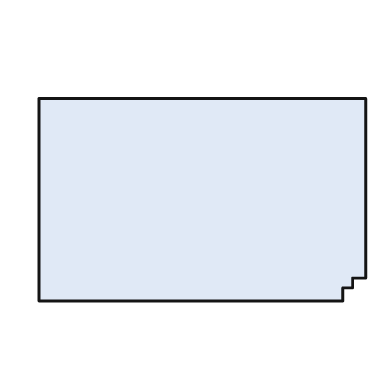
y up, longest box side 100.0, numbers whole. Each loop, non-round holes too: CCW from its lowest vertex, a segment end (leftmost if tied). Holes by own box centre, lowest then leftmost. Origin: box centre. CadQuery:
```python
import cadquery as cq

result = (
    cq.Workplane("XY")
    .moveTo(-50.0, -31.0)
    .lineTo(43.0, -31.0)
    .lineTo(43.0, -27.0)
    .lineTo(46.0, -27.0)
    .lineTo(46.0, -24.0)
    .lineTo(50.0, -24.0)
    .lineTo(50.0, 31.0)
    .lineTo(-50.0, 31.0)
    .close()
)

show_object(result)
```